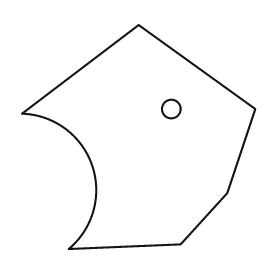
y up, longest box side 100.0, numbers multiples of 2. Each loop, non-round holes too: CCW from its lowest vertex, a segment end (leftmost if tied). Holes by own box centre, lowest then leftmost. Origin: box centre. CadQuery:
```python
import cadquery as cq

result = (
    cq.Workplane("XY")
    .moveTo(-30.0, -48.0)
    .lineTo(18.0, -46.0)
    .lineTo(38.0, -24.0)
    .lineTo(50.0, 12.0)
    .lineTo(0.0, 48.0)
    .lineTo(-50.0, 10.0)
    .threePointArc((-20.0, -12.0), (-30.0, -48.0))
    .close()
    .moveTo(14.0, 12.0)
    .circle(4.0)
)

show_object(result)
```